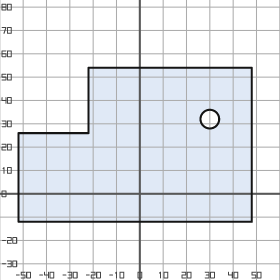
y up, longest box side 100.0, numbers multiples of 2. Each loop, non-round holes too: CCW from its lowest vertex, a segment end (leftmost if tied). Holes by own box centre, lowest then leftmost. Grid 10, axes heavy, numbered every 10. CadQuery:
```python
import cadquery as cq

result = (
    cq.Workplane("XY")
    .moveTo(-52.0, -12.0)
    .lineTo(48.0, -12.0)
    .lineTo(48.0, 54.0)
    .lineTo(-22.0, 54.0)
    .lineTo(-22.0, 26.0)
    .lineTo(-52.0, 26.0)
    .close()
    .moveTo(30.0, 32.0)
    .circle(4.0)
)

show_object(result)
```